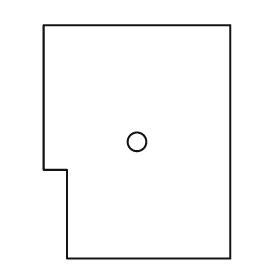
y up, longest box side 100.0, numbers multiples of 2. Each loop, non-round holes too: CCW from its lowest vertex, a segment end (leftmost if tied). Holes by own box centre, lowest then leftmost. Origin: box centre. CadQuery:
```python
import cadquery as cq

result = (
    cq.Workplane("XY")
    .moveTo(-30.0, -50.0)
    .lineTo(40.0, -50.0)
    .lineTo(40.0, 50.0)
    .lineTo(-40.0, 50.0)
    .lineTo(-40.0, -12.0)
    .lineTo(-30.0, -12.0)
    .close()
    .moveTo(0.0, 0.0)
    .circle(4.0)
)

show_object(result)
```